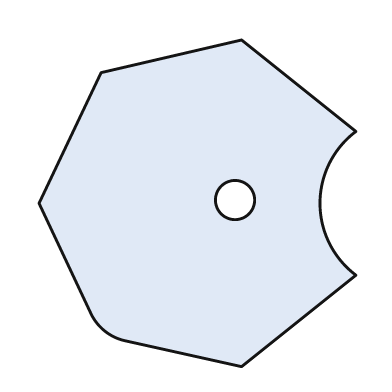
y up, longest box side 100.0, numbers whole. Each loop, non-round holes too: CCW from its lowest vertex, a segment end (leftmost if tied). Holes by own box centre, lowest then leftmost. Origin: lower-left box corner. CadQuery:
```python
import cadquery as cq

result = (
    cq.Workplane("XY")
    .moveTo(62.0, 0.0)
    .lineTo(97.0, 28.0)
    .threePointArc((86.0, 50.0), (97.0, 72.0))
    .lineTo(62.0, 100.0)
    .lineTo(19.0, 90.0)
    .lineTo(0.0, 50.0)
    .lineTo(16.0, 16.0)
    .threePointArc((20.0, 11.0), (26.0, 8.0))
    .close()
    .moveTo(60.0, 51.0)
    .circle(6.0)
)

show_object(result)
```